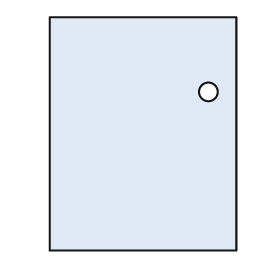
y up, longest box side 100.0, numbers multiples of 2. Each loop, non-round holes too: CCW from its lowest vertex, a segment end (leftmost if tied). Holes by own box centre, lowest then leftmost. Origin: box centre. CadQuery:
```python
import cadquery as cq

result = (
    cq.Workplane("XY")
    .moveTo(-40.0, -50.0)
    .lineTo(40.0, -50.0)
    .lineTo(40.0, 50.0)
    .lineTo(-40.0, 50.0)
    .close()
    .moveTo(28.0, 18.0)
    .circle(4.0)
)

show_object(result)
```